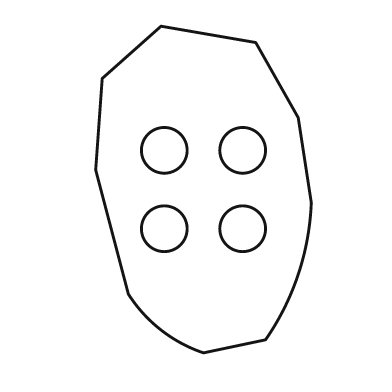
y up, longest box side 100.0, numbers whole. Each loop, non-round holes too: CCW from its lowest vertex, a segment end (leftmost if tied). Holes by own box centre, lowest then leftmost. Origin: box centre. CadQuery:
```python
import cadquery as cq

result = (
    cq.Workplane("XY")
    .moveTo(0.0, -50.0)
    .lineTo(19.0, -46.0)
    .threePointArc((29.0, -26.0), (33.0, -4.0))
    .lineTo(29.0, 22.0)
    .lineTo(16.0, 45.0)
    .lineTo(-13.0, 50.0)
    .lineTo(-31.0, 34.0)
    .lineTo(-33.0, 6.0)
    .lineTo(-23.0, -32.0)
    .threePointArc((-13.0, -43.0), (0.0, -50.0))
    .close()
    .moveTo(-12.0, -12.0)
    .circle(7.0)
    .moveTo(12.0, -12.0)
    .circle(7.0)
    .moveTo(-12.0, 12.0)
    .circle(7.0)
    .moveTo(12.0, 12.0)
    .circle(7.0)
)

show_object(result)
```